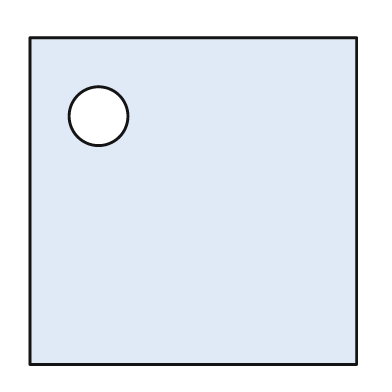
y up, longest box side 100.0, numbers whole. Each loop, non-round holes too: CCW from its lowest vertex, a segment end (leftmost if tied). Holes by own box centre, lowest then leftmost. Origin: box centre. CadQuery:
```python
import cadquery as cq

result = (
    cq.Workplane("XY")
    .moveTo(-50.0, -50.0)
    .lineTo(50.0, -50.0)
    .lineTo(50.0, 50.0)
    .lineTo(-50.0, 50.0)
    .close()
    .moveTo(-29.0, 26.0)
    .circle(9.0)
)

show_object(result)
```